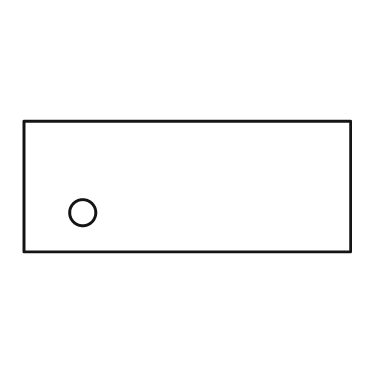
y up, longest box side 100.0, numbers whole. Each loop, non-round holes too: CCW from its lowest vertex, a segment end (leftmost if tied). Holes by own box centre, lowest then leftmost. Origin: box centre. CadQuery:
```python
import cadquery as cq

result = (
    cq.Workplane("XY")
    .moveTo(-50.0, -20.0)
    .lineTo(50.0, -20.0)
    .lineTo(50.0, 20.0)
    .lineTo(-50.0, 20.0)
    .close()
    .moveTo(-32.0, -8.0)
    .circle(4.0)
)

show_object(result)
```